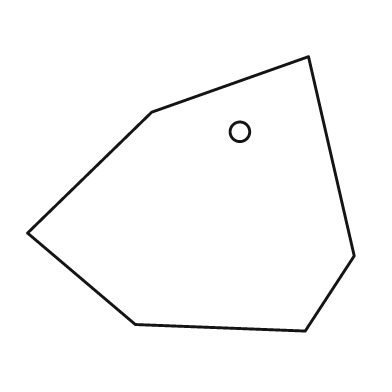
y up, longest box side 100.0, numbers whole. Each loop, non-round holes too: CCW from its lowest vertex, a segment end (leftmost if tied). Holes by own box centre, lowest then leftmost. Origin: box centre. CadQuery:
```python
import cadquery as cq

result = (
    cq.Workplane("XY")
    .moveTo(35.0, -42.0)
    .lineTo(50.0, -19.0)
    .lineTo(36.0, 42.0)
    .lineTo(-12.0, 25.0)
    .lineTo(-50.0, -12.0)
    .lineTo(-17.0, -40.0)
    .close()
    .moveTo(15.0, 19.0)
    .circle(3.0)
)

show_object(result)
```